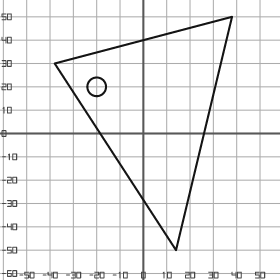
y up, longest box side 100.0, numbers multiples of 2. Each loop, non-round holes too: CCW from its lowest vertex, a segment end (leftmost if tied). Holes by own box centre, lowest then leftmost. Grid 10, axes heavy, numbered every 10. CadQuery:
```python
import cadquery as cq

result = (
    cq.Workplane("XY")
    .moveTo(14.0, -50.0)
    .lineTo(38.0, 50.0)
    .lineTo(-38.0, 30.0)
    .close()
    .moveTo(-20.0, 20.0)
    .circle(4.0)
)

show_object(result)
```